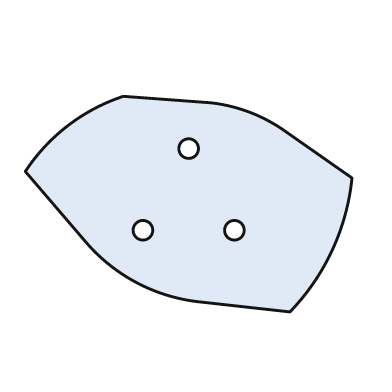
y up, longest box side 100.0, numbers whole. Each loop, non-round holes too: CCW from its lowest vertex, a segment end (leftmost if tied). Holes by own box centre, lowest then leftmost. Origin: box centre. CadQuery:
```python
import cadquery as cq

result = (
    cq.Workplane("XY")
    .moveTo(31.0, -33.0)
    .threePointArc((44.0, -14.0), (50.0, 8.0))
    .lineTo(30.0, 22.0)
    .threePointArc((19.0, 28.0), (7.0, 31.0))
    .lineTo(-20.0, 33.0)
    .threePointArc((-37.0, 24.0), (-50.0, 10.0))
    .lineTo(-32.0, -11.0)
    .threePointArc((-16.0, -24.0), (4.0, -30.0))
    .close()
    .moveTo(-14.0, -8.0)
    .circle(3.0)
    .moveTo(14.0, -8.0)
    .circle(3.0)
    .moveTo(0.0, 17.0)
    .circle(3.0)
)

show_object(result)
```